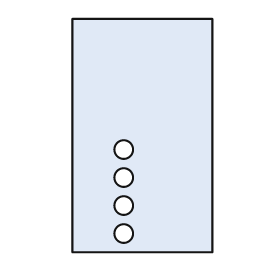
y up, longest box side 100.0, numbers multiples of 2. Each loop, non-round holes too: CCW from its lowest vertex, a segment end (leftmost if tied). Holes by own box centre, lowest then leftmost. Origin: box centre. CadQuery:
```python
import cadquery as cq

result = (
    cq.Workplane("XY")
    .moveTo(-30.0, -50.0)
    .lineTo(30.0, -50.0)
    .lineTo(30.0, 50.0)
    .lineTo(-30.0, 50.0)
    .close()
    .moveTo(-8.0, -42.0)
    .circle(4.0)
    .moveTo(-8.0, -30.0)
    .circle(4.0)
    .moveTo(-8.0, -18.0)
    .circle(4.0)
    .moveTo(-8.0, -6.0)
    .circle(4.0)
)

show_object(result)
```